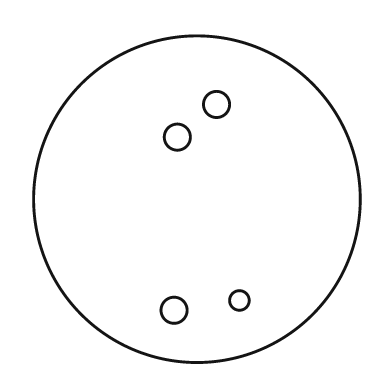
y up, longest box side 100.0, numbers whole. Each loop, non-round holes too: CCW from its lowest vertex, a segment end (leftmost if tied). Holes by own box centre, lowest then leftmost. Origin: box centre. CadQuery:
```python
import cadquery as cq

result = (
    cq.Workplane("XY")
    .moveTo(0.0, 0.0)
    .circle(50.0)
    .moveTo(-7.0, -34.0)
    .circle(4.0)
    .moveTo(13.0, -31.0)
    .circle(3.0)
    .moveTo(-6.0, 19.0)
    .circle(4.0)
    .moveTo(6.0, 29.0)
    .circle(4.0)
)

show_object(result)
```